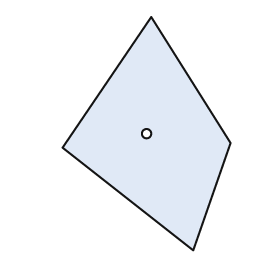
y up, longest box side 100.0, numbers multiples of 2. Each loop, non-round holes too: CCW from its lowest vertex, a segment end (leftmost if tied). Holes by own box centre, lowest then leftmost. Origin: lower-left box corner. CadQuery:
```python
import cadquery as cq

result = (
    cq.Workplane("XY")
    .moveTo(56.0, 0.0)
    .lineTo(72.0, 46.0)
    .lineTo(38.0, 100.0)
    .lineTo(0.0, 44.0)
    .close()
    .moveTo(36.0, 50.0)
    .circle(2.0)
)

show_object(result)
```